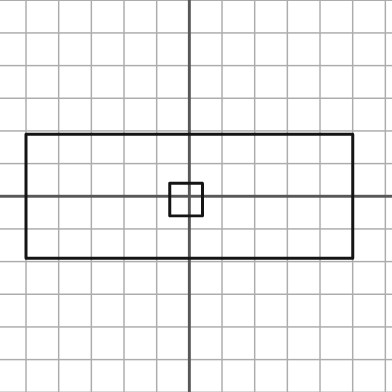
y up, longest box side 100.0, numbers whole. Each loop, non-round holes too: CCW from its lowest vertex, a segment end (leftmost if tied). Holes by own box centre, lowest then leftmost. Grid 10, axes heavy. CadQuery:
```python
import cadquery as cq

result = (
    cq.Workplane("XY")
    .moveTo(-50.0, -19.0)
    .lineTo(50.0, -19.0)
    .lineTo(50.0, 19.0)
    .lineTo(-50.0, 19.0)
    .close()
    .moveTo(-6.0, -6.0)
    .lineTo(4.0, -6.0)
    .lineTo(4.0, 4.0)
    .lineTo(-6.0, 4.0)
    .close()
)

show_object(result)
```